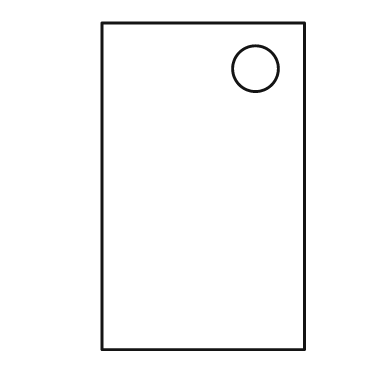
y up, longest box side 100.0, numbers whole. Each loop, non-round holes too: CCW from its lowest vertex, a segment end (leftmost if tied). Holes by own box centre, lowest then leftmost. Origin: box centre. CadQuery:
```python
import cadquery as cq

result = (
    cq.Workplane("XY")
    .moveTo(-31.0, -50.0)
    .lineTo(31.0, -50.0)
    .lineTo(31.0, 50.0)
    .lineTo(-31.0, 50.0)
    .close()
    .moveTo(16.0, 36.0)
    .circle(7.0)
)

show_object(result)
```